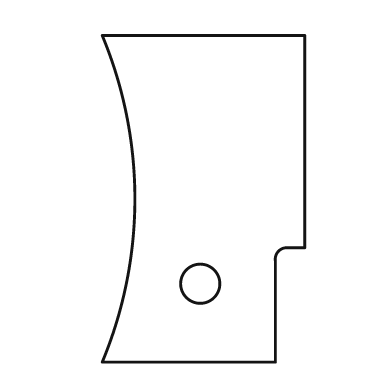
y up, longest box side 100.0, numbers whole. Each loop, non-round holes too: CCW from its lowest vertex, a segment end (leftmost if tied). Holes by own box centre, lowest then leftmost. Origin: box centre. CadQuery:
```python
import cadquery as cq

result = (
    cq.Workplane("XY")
    .moveTo(-31.0, -50.0)
    .lineTo(22.0, -50.0)
    .lineTo(22.0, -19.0)
    .threePointArc((23.0, -16.0), (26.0, -15.0))
    .lineTo(31.0, -15.0)
    .lineTo(31.0, 50.0)
    .lineTo(-31.0, 50.0)
    .threePointArc((-21.0, 0.0), (-31.0, -50.0))
    .close()
    .moveTo(-1.0, -26.0)
    .circle(6.0)
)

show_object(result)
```